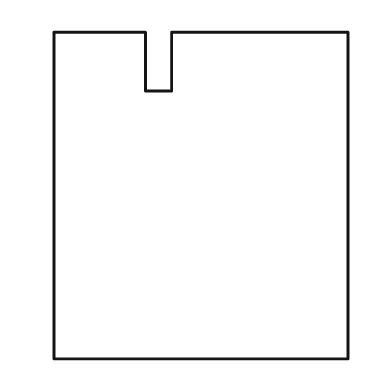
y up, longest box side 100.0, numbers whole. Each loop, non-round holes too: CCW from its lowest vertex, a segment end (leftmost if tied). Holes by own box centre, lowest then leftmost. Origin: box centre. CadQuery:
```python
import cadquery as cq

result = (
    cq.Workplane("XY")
    .moveTo(-45.0, -50.0)
    .lineTo(45.0, -50.0)
    .lineTo(45.0, 50.0)
    .lineTo(-9.0, 50.0)
    .lineTo(-9.0, 32.0)
    .lineTo(-17.0, 32.0)
    .lineTo(-17.0, 50.0)
    .lineTo(-45.0, 50.0)
    .close()
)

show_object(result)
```